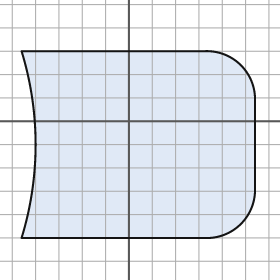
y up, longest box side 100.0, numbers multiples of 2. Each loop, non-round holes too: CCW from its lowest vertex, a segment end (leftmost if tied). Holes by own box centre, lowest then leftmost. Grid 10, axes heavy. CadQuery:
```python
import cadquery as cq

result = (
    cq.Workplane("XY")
    .moveTo(-46.0, -50.0)
    .lineTo(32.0, -50.0)
    .threePointArc((48.0, -44.0), (54.0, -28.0))
    .lineTo(54.0, 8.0)
    .threePointArc((48.0, 24.0), (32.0, 30.0))
    .lineTo(-46.0, 30.0)
    .threePointArc((-40.0, -10.0), (-46.0, -50.0))
    .close()
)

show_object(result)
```